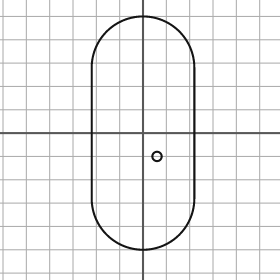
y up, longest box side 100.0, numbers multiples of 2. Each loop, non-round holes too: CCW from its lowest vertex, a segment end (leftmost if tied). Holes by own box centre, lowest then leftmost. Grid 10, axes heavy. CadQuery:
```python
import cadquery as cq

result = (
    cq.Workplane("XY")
    .moveTo(-22.0, -28.0)
    .threePointArc((0.0, -50.0), (22.0, -28.0))
    .lineTo(22.0, 28.0)
    .threePointArc((0.0, 50.0), (-22.0, 28.0))
    .close()
    .moveTo(6.0, -10.0)
    .circle(2.0)
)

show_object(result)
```